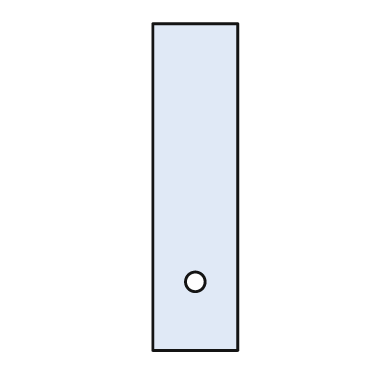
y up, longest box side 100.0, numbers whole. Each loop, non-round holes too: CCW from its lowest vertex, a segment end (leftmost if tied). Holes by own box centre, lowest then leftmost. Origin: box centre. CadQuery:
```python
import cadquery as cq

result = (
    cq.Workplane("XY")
    .moveTo(-13.0, -50.0)
    .lineTo(13.0, -50.0)
    .lineTo(13.0, 50.0)
    .lineTo(-13.0, 50.0)
    .close()
    .moveTo(0.0, -29.0)
    .circle(3.0)
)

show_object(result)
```